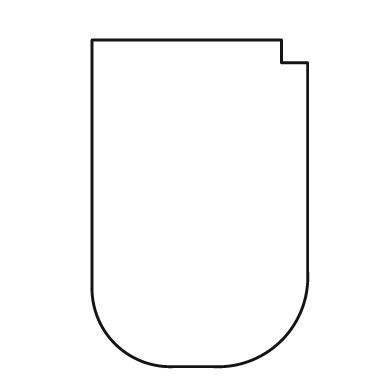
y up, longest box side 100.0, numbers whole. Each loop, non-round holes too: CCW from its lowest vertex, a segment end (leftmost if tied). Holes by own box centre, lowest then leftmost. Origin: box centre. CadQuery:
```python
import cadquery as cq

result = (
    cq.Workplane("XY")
    .moveTo(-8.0, -50.0)
    .lineTo(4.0, -50.0)
    .threePointArc((25.0, -42.0), (33.0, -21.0))
    .lineTo(33.0, 43.0)
    .lineTo(25.0, 43.0)
    .lineTo(25.0, 50.0)
    .lineTo(-33.0, 50.0)
    .lineTo(-33.0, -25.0)
    .threePointArc((-26.0, -43.0), (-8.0, -50.0))
    .close()
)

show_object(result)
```